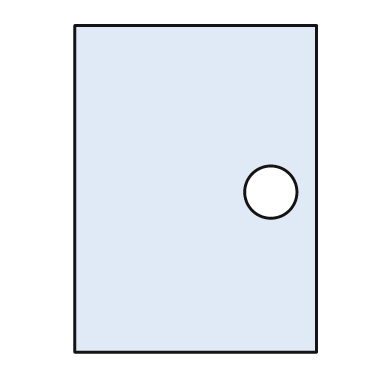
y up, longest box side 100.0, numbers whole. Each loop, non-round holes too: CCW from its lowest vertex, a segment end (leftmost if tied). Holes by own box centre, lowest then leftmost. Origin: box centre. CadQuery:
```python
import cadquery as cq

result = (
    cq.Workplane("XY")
    .moveTo(-37.0, -50.0)
    .lineTo(37.0, -50.0)
    .lineTo(37.0, 50.0)
    .lineTo(-37.0, 50.0)
    .close()
    .moveTo(23.0, -1.0)
    .circle(8.0)
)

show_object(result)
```